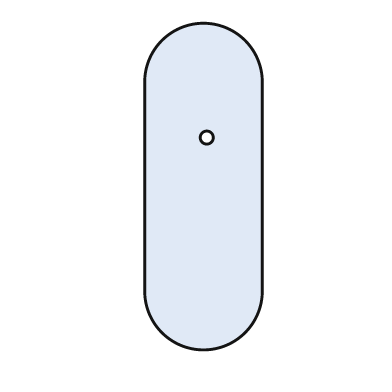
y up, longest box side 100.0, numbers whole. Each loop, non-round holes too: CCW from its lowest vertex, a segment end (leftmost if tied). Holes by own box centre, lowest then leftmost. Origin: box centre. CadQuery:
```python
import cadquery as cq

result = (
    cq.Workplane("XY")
    .moveTo(-18.0, -32.0)
    .threePointArc((0.0, -50.0), (18.0, -32.0))
    .lineTo(18.0, 32.0)
    .threePointArc((0.0, 50.0), (-18.0, 32.0))
    .close()
    .moveTo(1.0, 15.0)
    .circle(2.0)
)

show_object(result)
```